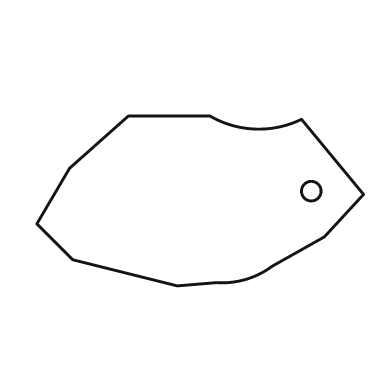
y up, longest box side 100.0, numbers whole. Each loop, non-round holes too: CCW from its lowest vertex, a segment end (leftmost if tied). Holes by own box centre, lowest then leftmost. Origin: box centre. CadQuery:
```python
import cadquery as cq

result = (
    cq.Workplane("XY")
    .moveTo(-7.0, -26.0)
    .lineTo(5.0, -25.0)
    .threePointArc((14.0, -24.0), (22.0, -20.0))
    .lineTo(38.0, -11.0)
    .lineTo(50.0, 2.0)
    .lineTo(31.0, 25.0)
    .threePointArc((17.0, 22.0), (3.0, 26.0))
    .lineTo(-22.0, 26.0)
    .lineTo(-40.0, 10.0)
    .lineTo(-50.0, -7.0)
    .lineTo(-39.0, -18.0)
    .close()
    .moveTo(34.0, 3.0)
    .circle(3.0)
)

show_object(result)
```